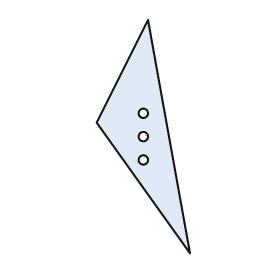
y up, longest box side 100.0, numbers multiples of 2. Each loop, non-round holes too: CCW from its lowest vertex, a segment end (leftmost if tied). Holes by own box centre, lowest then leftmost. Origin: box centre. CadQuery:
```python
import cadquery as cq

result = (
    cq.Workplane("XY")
    .moveTo(20.0, -50.0)
    .lineTo(2.0, 50.0)
    .lineTo(-20.0, 6.0)
    .close()
    .moveTo(0.0, -10.0)
    .circle(2.0)
    .moveTo(0.0, 0.0)
    .circle(2.0)
    .moveTo(0.0, 10.0)
    .circle(2.0)
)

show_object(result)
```